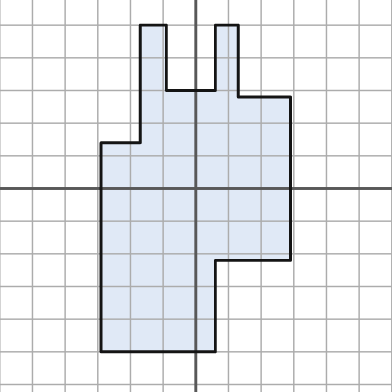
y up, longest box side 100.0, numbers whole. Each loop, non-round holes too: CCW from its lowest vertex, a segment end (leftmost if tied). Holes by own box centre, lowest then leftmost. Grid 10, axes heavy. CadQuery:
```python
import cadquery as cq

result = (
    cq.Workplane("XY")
    .moveTo(-29.0, -50.0)
    .lineTo(6.0, -50.0)
    .lineTo(6.0, -22.0)
    .lineTo(29.0, -22.0)
    .lineTo(29.0, 28.0)
    .lineTo(13.0, 28.0)
    .lineTo(13.0, 50.0)
    .lineTo(6.0, 50.0)
    .lineTo(6.0, 30.0)
    .lineTo(-9.0, 30.0)
    .lineTo(-9.0, 50.0)
    .lineTo(-17.0, 50.0)
    .lineTo(-17.0, 14.0)
    .lineTo(-29.0, 14.0)
    .close()
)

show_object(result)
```